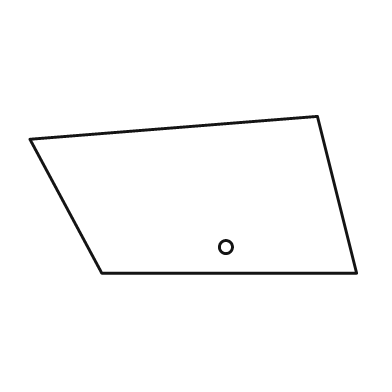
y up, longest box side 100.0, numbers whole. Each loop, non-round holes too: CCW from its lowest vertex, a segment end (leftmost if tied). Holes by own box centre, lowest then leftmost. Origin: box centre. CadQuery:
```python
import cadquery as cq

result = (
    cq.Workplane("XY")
    .moveTo(-28.0, -24.0)
    .lineTo(50.0, -24.0)
    .lineTo(38.0, 24.0)
    .lineTo(-50.0, 17.0)
    .close()
    .moveTo(10.0, -16.0)
    .circle(2.0)
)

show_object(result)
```